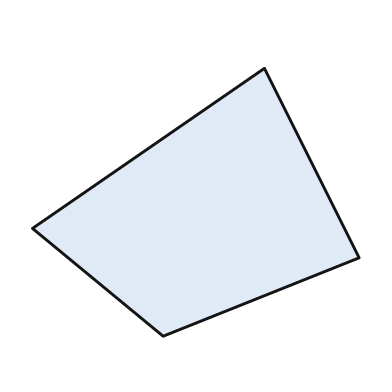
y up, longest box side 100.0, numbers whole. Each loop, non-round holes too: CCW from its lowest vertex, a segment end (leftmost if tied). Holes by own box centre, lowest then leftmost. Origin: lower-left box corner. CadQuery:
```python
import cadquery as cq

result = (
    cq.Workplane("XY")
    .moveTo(40.0, 0.0)
    .lineTo(100.0, 24.0)
    .lineTo(71.0, 82.0)
    .lineTo(0.0, 33.0)
    .close()
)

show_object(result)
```